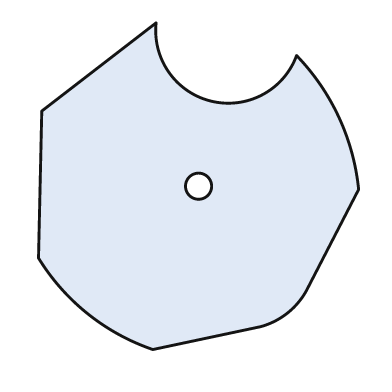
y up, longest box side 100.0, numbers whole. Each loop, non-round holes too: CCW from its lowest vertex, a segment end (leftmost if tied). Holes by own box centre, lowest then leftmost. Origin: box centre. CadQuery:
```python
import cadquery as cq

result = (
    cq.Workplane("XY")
    .moveTo(-14.0, -50.0)
    .lineTo(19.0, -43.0)
    .threePointArc((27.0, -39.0), (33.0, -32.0))
    .lineTo(49.0, -1.0)
    .threePointArc((43.0, 21.0), (30.0, 40.0))
    .threePointArc((4.0, 26.0), (-13.0, 50.0))
    .lineTo(-48.0, 23.0)
    .lineTo(-49.0, -22.0)
    .threePointArc((-34.0, -39.0), (-14.0, -50.0))
    .close()
    .moveTo(0.0, 0.0)
    .circle(4.0)
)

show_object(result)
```